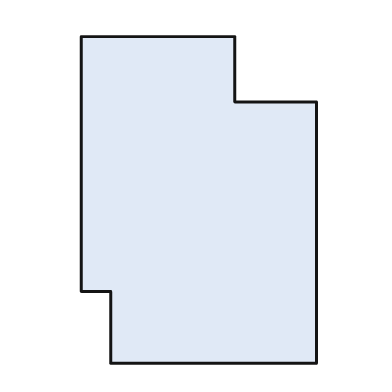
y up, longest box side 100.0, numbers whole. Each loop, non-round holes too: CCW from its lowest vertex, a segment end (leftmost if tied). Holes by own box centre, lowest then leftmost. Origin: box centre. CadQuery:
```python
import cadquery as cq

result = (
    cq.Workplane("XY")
    .moveTo(-27.0, -50.0)
    .lineTo(36.0, -50.0)
    .lineTo(36.0, 30.0)
    .lineTo(11.0, 30.0)
    .lineTo(11.0, 50.0)
    .lineTo(-36.0, 50.0)
    .lineTo(-36.0, -28.0)
    .lineTo(-27.0, -28.0)
    .close()
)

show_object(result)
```